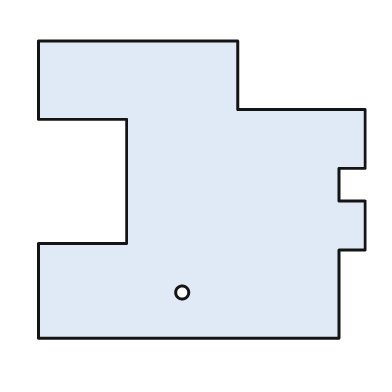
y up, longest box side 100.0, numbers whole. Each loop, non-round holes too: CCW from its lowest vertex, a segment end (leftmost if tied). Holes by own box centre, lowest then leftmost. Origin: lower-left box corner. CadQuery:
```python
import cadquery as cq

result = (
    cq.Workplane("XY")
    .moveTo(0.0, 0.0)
    .lineTo(92.0, 0.0)
    .lineTo(92.0, 27.0)
    .lineTo(100.0, 27.0)
    .lineTo(100.0, 42.0)
    .lineTo(92.0, 42.0)
    .lineTo(92.0, 52.0)
    .lineTo(100.0, 52.0)
    .lineTo(100.0, 70.0)
    .lineTo(61.0, 70.0)
    .lineTo(61.0, 91.0)
    .lineTo(0.0, 91.0)
    .lineTo(0.0, 67.0)
    .lineTo(27.0, 67.0)
    .lineTo(27.0, 29.0)
    .lineTo(0.0, 29.0)
    .close()
    .moveTo(44.0, 14.0)
    .circle(2.0)
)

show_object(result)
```